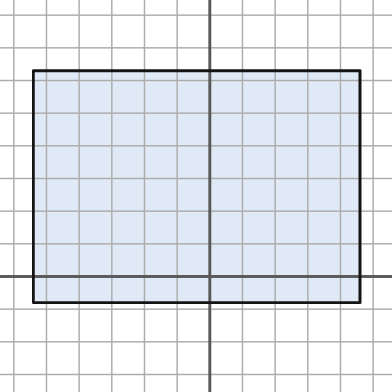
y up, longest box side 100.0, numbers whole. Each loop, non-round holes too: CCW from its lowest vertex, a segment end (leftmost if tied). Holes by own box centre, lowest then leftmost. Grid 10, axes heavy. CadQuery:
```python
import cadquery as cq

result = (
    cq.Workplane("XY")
    .moveTo(-54.0, -8.0)
    .lineTo(46.0, -8.0)
    .lineTo(46.0, 63.0)
    .lineTo(-54.0, 63.0)
    .close()
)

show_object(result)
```